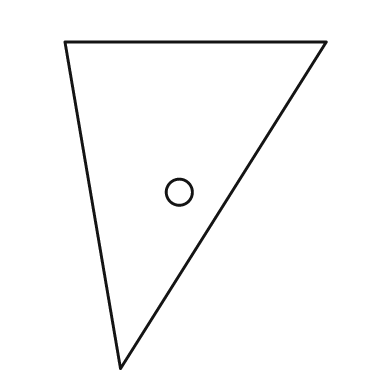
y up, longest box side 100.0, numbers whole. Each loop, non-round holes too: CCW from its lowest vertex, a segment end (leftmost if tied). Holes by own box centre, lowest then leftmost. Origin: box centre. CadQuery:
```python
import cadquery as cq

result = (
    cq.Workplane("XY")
    .moveTo(-23.0, -50.0)
    .lineTo(40.0, 50.0)
    .lineTo(-40.0, 50.0)
    .close()
    .moveTo(-5.0, 4.0)
    .circle(4.0)
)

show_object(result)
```